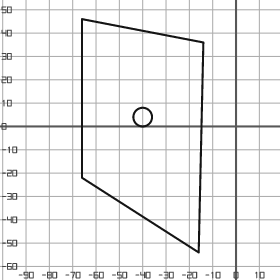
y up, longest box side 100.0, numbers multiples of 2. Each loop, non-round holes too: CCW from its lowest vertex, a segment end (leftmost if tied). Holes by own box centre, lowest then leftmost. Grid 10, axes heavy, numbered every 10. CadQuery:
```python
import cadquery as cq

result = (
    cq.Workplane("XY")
    .moveTo(-16.0, -54.0)
    .lineTo(-14.0, 36.0)
    .lineTo(-66.0, 46.0)
    .lineTo(-66.0, -22.0)
    .close()
    .moveTo(-40.0, 4.0)
    .circle(4.0)
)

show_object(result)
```